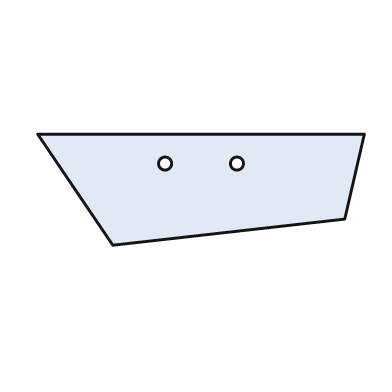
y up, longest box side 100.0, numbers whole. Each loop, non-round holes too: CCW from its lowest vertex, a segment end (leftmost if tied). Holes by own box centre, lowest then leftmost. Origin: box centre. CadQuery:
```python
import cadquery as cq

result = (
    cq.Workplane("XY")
    .moveTo(-27.0, -17.0)
    .lineTo(44.0, -9.0)
    .lineTo(50.0, 17.0)
    .lineTo(-50.0, 17.0)
    .close()
    .moveTo(-11.0, 8.0)
    .circle(2.0)
    .moveTo(11.0, 8.0)
    .circle(2.0)
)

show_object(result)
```